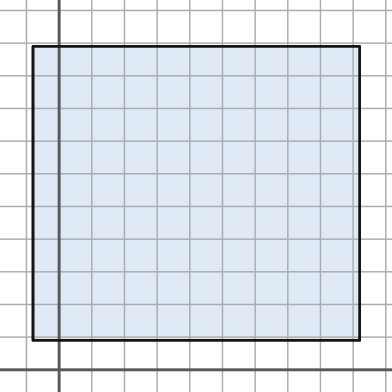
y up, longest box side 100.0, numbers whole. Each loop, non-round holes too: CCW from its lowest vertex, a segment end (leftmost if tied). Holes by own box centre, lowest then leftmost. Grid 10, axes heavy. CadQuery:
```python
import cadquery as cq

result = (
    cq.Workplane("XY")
    .moveTo(-8.0, 9.0)
    .lineTo(92.0, 9.0)
    .lineTo(92.0, 99.0)
    .lineTo(-8.0, 99.0)
    .close()
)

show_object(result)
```